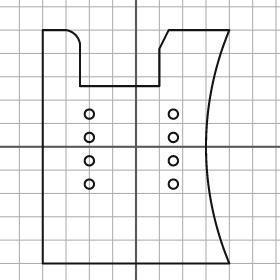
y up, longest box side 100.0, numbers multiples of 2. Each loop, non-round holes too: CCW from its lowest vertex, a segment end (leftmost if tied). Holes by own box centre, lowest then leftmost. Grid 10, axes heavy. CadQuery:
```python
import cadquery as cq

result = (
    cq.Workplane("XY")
    .moveTo(-40.0, -50.0)
    .lineTo(40.0, -50.0)
    .threePointArc((30.0, 0.0), (40.0, 50.0))
    .lineTo(14.0, 50.0)
    .lineTo(10.0, 42.0)
    .lineTo(10.0, 26.0)
    .lineTo(-24.0, 26.0)
    .lineTo(-24.0, 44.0)
    .threePointArc((-26.0, 48.0), (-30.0, 50.0))
    .lineTo(-40.0, 50.0)
    .close()
    .moveTo(-20.0, -16.0)
    .circle(2.0)
    .moveTo(16.0, -16.0)
    .circle(2.0)
    .moveTo(-20.0, -6.0)
    .circle(2.0)
    .moveTo(16.0, -6.0)
    .circle(2.0)
    .moveTo(-20.0, 4.0)
    .circle(2.0)
    .moveTo(16.0, 4.0)
    .circle(2.0)
    .moveTo(-20.0, 14.0)
    .circle(2.0)
    .moveTo(16.0, 14.0)
    .circle(2.0)
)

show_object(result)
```